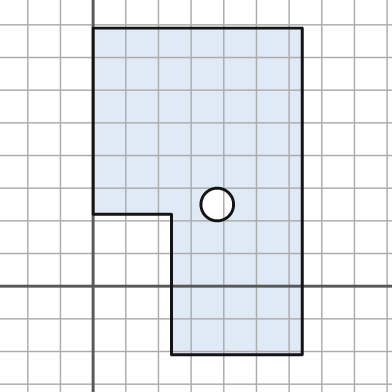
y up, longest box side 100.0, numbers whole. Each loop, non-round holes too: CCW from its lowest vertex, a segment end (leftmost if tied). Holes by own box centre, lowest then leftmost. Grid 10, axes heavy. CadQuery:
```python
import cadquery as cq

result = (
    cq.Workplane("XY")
    .moveTo(24.0, -21.0)
    .lineTo(64.0, -21.0)
    .lineTo(64.0, 79.0)
    .lineTo(0.0, 79.0)
    .lineTo(0.0, 22.0)
    .lineTo(24.0, 22.0)
    .close()
    .moveTo(38.0, 25.0)
    .circle(5.0)
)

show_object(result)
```